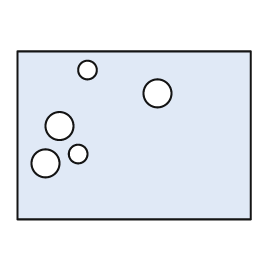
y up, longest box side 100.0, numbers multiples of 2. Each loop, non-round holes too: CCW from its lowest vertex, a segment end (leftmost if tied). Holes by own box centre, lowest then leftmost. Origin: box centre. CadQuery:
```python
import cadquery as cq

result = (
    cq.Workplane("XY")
    .moveTo(-50.0, -36.0)
    .lineTo(50.0, -36.0)
    .lineTo(50.0, 36.0)
    .lineTo(-50.0, 36.0)
    .close()
    .moveTo(-38.0, -12.0)
    .circle(6.0)
    .moveTo(-24.0, -8.0)
    .circle(4.0)
    .moveTo(-32.0, 4.0)
    .circle(6.0)
    .moveTo(10.0, 18.0)
    .circle(6.0)
    .moveTo(-20.0, 28.0)
    .circle(4.0)
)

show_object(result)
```